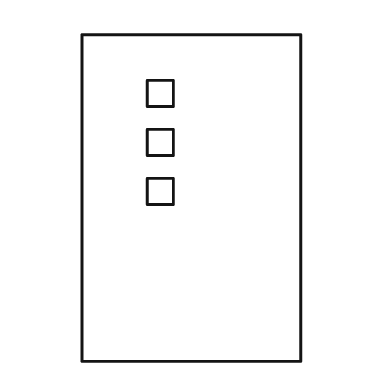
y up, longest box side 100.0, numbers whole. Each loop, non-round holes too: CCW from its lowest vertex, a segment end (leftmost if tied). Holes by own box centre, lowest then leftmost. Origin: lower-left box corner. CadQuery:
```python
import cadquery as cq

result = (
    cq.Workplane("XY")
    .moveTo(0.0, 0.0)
    .lineTo(67.0, 0.0)
    .lineTo(67.0, 100.0)
    .lineTo(0.0, 100.0)
    .close()
    .moveTo(20.0, 48.0)
    .lineTo(28.0, 48.0)
    .lineTo(28.0, 56.0)
    .lineTo(20.0, 56.0)
    .close()
    .moveTo(20.0, 63.0)
    .lineTo(28.0, 63.0)
    .lineTo(28.0, 71.0)
    .lineTo(20.0, 71.0)
    .close()
    .moveTo(20.0, 78.0)
    .lineTo(28.0, 78.0)
    .lineTo(28.0, 86.0)
    .lineTo(20.0, 86.0)
    .close()
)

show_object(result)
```